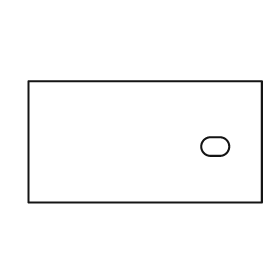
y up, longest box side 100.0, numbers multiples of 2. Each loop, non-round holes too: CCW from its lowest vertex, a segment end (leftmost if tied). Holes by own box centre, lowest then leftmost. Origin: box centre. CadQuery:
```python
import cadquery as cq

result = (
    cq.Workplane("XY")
    .moveTo(-50.0, -26.0)
    .lineTo(50.0, -26.0)
    .lineTo(50.0, 26.0)
    .lineTo(-50.0, 26.0)
    .close()
    .moveTo(28.0, -6.0)
    .lineTo(32.0, -6.0)
    .threePointArc((36.0, -2.0), (32.0, 2.0))
    .lineTo(28.0, 2.0)
    .threePointArc((24.0, -2.0), (28.0, -6.0))
    .close()
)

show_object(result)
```